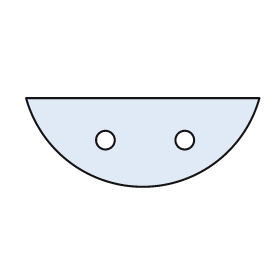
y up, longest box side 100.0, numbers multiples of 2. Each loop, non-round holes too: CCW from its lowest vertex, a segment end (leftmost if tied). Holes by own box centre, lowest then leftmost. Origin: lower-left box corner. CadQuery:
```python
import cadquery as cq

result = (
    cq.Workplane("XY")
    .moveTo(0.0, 38.0)
    .threePointArc((50.0, 0.0), (100.0, 38.0))
    .close()
    .moveTo(34.0, 20.0)
    .circle(4.0)
    .moveTo(68.0, 20.0)
    .circle(4.0)
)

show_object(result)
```